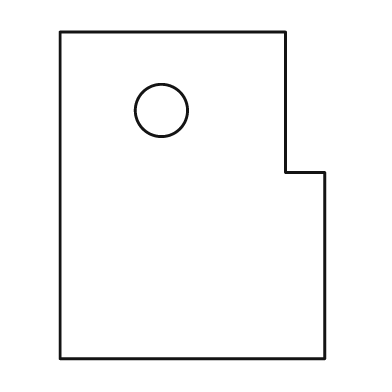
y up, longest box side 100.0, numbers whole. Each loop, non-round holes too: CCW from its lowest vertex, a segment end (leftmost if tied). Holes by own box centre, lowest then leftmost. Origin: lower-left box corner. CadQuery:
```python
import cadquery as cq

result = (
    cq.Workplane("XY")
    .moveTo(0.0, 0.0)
    .lineTo(81.0, 0.0)
    .lineTo(81.0, 57.0)
    .lineTo(69.0, 57.0)
    .lineTo(69.0, 100.0)
    .lineTo(0.0, 100.0)
    .close()
    .moveTo(31.0, 76.0)
    .circle(8.0)
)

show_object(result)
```